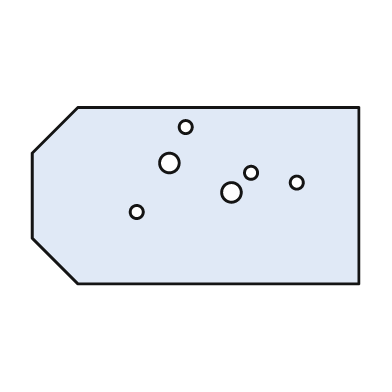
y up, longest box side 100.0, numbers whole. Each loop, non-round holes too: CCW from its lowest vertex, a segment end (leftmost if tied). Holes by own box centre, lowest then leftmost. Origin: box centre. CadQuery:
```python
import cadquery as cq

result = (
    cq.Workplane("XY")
    .moveTo(-36.0, -27.0)
    .lineTo(50.0, -27.0)
    .lineTo(50.0, 27.0)
    .lineTo(-36.0, 27.0)
    .lineTo(-50.0, 13.0)
    .lineTo(-50.0, -13.0)
    .close()
    .moveTo(-18.0, -5.0)
    .circle(2.0)
    .moveTo(11.0, 1.0)
    .circle(3.0)
    .moveTo(31.0, 4.0)
    .circle(2.0)
    .moveTo(17.0, 7.0)
    .circle(2.0)
    .moveTo(-8.0, 10.0)
    .circle(3.0)
    .moveTo(-3.0, 21.0)
    .circle(2.0)
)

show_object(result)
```